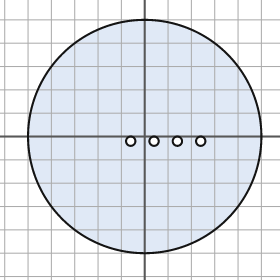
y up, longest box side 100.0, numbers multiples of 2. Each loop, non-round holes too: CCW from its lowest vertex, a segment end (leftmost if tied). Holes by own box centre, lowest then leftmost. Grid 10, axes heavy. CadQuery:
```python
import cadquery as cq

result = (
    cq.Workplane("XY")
    .moveTo(0.0, 0.0)
    .circle(50.0)
    .moveTo(-6.0, -2.0)
    .circle(2.0)
    .moveTo(4.0, -2.0)
    .circle(2.0)
    .moveTo(14.0, -2.0)
    .circle(2.0)
    .moveTo(24.0, -2.0)
    .circle(2.0)
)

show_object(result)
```